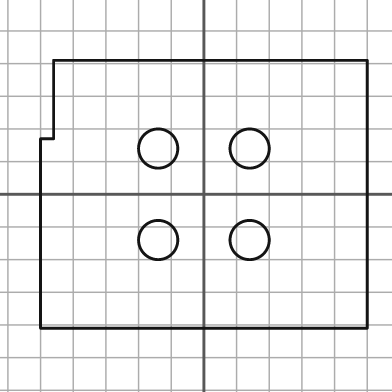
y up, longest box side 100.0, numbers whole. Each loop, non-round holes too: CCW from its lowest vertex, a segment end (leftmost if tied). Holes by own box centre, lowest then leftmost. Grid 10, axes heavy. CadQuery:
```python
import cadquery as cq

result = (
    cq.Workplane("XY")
    .moveTo(-50.0, -41.0)
    .lineTo(50.0, -41.0)
    .lineTo(50.0, 41.0)
    .lineTo(-46.0, 41.0)
    .lineTo(-46.0, 17.0)
    .lineTo(-50.0, 17.0)
    .close()
    .moveTo(-14.0, -14.0)
    .circle(6.0)
    .moveTo(14.0, -14.0)
    .circle(6.0)
    .moveTo(-14.0, 14.0)
    .circle(6.0)
    .moveTo(14.0, 14.0)
    .circle(6.0)
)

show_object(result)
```